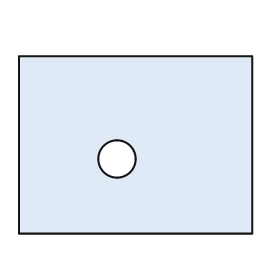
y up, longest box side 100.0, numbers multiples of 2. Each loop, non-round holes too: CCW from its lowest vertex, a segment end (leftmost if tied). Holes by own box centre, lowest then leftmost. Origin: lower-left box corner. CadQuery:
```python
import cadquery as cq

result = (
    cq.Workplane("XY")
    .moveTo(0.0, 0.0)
    .lineTo(100.0, 0.0)
    .lineTo(100.0, 76.0)
    .lineTo(0.0, 76.0)
    .close()
    .moveTo(42.0, 32.0)
    .circle(8.0)
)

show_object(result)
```